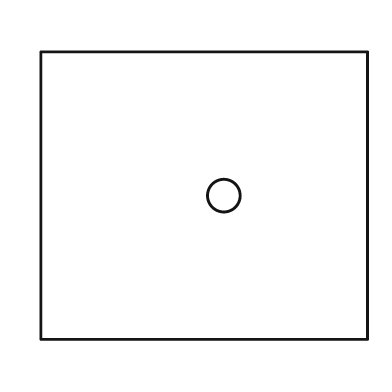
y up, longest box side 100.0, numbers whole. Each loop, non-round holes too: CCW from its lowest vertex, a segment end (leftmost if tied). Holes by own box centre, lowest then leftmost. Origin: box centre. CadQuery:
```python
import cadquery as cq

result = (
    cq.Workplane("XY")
    .moveTo(-50.0, -44.0)
    .lineTo(50.0, -44.0)
    .lineTo(50.0, 44.0)
    .lineTo(-50.0, 44.0)
    .close()
    .moveTo(6.0, 0.0)
    .circle(5.0)
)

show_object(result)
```